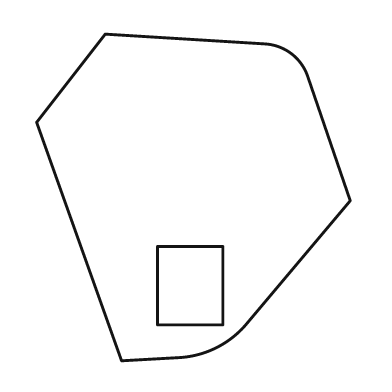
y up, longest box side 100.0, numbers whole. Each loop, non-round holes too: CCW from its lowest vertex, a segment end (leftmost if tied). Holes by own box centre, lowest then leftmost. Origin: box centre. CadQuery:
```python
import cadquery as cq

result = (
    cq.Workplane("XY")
    .moveTo(-22.0, -50.0)
    .lineTo(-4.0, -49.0)
    .threePointArc((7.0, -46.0), (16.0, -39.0))
    .lineTo(48.0, -1.0)
    .lineTo(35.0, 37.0)
    .threePointArc((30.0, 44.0), (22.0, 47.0))
    .lineTo(-27.0, 50.0)
    .lineTo(-48.0, 23.0)
    .close()
    .moveTo(-11.0, -39.0)
    .lineTo(9.0, -39.0)
    .lineTo(9.0, -15.0)
    .lineTo(-11.0, -15.0)
    .close()
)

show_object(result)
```